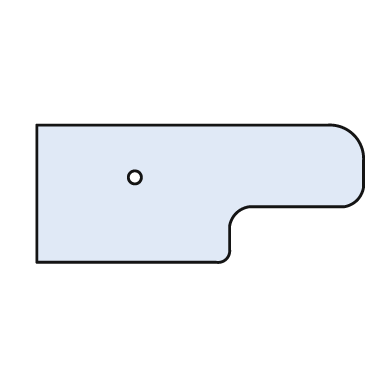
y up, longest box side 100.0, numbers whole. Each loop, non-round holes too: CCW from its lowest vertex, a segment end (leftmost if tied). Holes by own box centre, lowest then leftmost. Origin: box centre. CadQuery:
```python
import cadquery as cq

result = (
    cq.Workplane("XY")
    .moveTo(-50.0, -21.0)
    .lineTo(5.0, -21.0)
    .threePointArc((8.0, -20.0), (9.0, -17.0))
    .lineTo(9.0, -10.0)
    .threePointArc((11.0, -6.0), (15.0, -4.0))
    .lineTo(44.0, -4.0)
    .threePointArc((48.0, -2.0), (50.0, 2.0))
    .lineTo(50.0, 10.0)
    .threePointArc((47.0, 18.0), (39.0, 21.0))
    .lineTo(-50.0, 21.0)
    .close()
    .moveTo(-20.0, 5.0)
    .circle(2.0)
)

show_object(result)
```